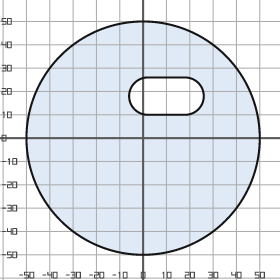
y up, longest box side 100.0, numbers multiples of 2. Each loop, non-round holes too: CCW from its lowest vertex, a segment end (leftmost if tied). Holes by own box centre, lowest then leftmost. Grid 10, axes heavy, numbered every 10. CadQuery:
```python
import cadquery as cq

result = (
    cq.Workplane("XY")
    .moveTo(0.0, 0.0)
    .circle(50.0)
    .moveTo(2.0, 10.0)
    .lineTo(18.0, 10.0)
    .threePointArc((26.0, 18.0), (18.0, 26.0))
    .lineTo(2.0, 26.0)
    .threePointArc((-6.0, 18.0), (2.0, 10.0))
    .close()
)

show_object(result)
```